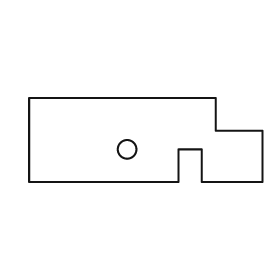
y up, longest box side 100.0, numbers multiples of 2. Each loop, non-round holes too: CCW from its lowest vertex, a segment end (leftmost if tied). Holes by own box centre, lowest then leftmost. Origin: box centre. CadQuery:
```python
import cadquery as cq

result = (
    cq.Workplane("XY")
    .moveTo(-50.0, -18.0)
    .lineTo(14.0, -18.0)
    .lineTo(14.0, -4.0)
    .lineTo(24.0, -4.0)
    .lineTo(24.0, -18.0)
    .lineTo(50.0, -18.0)
    .lineTo(50.0, 4.0)
    .lineTo(30.0, 4.0)
    .lineTo(30.0, 18.0)
    .lineTo(-50.0, 18.0)
    .close()
    .moveTo(-8.0, -4.0)
    .circle(4.0)
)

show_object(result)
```